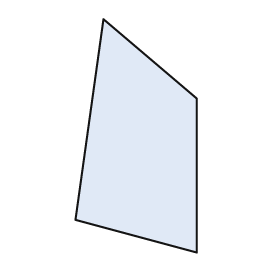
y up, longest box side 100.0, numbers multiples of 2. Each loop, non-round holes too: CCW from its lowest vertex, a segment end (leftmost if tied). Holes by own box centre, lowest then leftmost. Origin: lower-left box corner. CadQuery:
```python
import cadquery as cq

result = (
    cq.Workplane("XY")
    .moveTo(52.0, 0.0)
    .lineTo(52.0, 66.0)
    .lineTo(12.0, 100.0)
    .lineTo(0.0, 14.0)
    .close()
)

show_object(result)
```